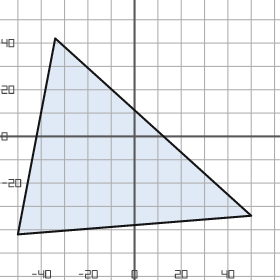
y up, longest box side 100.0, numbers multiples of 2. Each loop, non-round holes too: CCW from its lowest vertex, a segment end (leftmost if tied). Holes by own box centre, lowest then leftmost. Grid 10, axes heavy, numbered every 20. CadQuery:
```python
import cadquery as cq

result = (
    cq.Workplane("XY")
    .moveTo(-50.0, -42.0)
    .lineTo(50.0, -34.0)
    .lineTo(-34.0, 42.0)
    .close()
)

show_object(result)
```